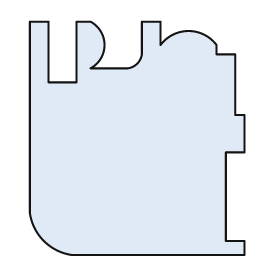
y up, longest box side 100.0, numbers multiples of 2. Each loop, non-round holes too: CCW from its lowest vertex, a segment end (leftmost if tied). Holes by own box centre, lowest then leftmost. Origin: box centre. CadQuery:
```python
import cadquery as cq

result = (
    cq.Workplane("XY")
    .moveTo(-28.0, -50.0)
    .lineTo(46.0, -50.0)
    .lineTo(46.0, -44.0)
    .lineTo(38.0, -44.0)
    .lineTo(38.0, -6.0)
    .lineTo(46.0, -6.0)
    .lineTo(46.0, 10.0)
    .lineTo(42.0, 10.0)
    .lineTo(42.0, 36.0)
    .lineTo(34.0, 36.0)
    .lineTo(34.0, 40.0)
    .threePointArc((22.0, 46.0), (10.0, 40.0))
    .lineTo(10.0, 50.0)
    .lineTo(2.0, 50.0)
    .lineTo(2.0, 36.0)
    .threePointArc((0.0, 32.0), (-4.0, 30.0))
    .lineTo(-20.0, 30.0)
    .threePointArc((-14.0, 40.0), (-20.0, 50.0))
    .lineTo(-26.0, 50.0)
    .lineTo(-26.0, 24.0)
    .lineTo(-38.0, 24.0)
    .lineTo(-38.0, 50.0)
    .lineTo(-46.0, 50.0)
    .lineTo(-46.0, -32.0)
    .threePointArc((-40.0, -44.0), (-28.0, -50.0))
    .close()
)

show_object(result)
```